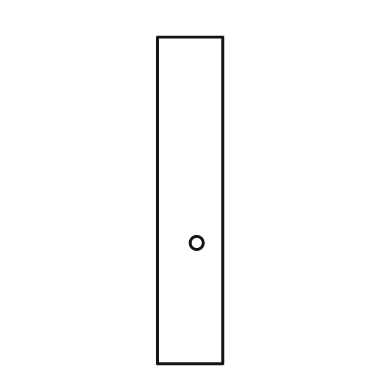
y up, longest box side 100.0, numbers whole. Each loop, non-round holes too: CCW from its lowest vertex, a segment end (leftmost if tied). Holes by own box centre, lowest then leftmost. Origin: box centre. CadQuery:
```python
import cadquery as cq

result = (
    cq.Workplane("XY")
    .moveTo(-10.0, -50.0)
    .lineTo(10.0, -50.0)
    .lineTo(10.0, 50.0)
    .lineTo(-10.0, 50.0)
    .close()
    .moveTo(2.0, -13.0)
    .circle(2.0)
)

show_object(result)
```